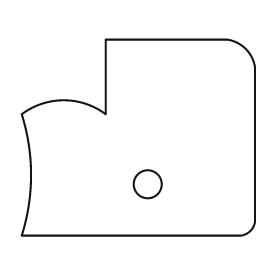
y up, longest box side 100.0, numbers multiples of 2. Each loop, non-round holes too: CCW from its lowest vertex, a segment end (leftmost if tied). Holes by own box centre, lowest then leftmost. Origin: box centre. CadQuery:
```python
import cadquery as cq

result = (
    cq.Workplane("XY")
    .moveTo(-50.0, -42.0)
    .lineTo(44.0, -42.0)
    .threePointArc((48.0, -40.0), (50.0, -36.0))
    .lineTo(50.0, 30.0)
    .threePointArc((46.0, 38.0), (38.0, 42.0))
    .lineTo(-14.0, 42.0)
    .lineTo(-14.0, 10.0)
    .threePointArc((-32.0, 16.0), (-50.0, 10.0))
    .threePointArc((-46.0, -16.0), (-50.0, -42.0))
    .close()
    .moveTo(4.0, -20.0)
    .circle(6.0)
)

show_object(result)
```